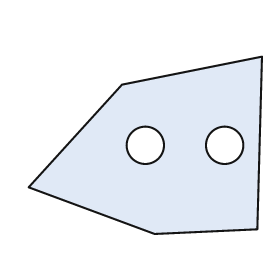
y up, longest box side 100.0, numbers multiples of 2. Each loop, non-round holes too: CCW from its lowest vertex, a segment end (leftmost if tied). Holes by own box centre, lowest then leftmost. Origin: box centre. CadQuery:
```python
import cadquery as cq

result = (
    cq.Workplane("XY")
    .moveTo(4.0, -38.0)
    .lineTo(48.0, -36.0)
    .lineTo(50.0, 38.0)
    .lineTo(-10.0, 26.0)
    .lineTo(-50.0, -18.0)
    .close()
    .moveTo(0.0, 0.0)
    .circle(8.0)
    .moveTo(34.0, 0.0)
    .circle(8.0)
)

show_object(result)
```